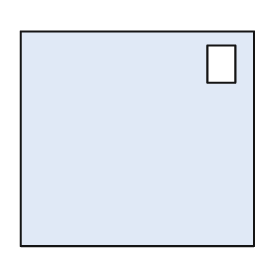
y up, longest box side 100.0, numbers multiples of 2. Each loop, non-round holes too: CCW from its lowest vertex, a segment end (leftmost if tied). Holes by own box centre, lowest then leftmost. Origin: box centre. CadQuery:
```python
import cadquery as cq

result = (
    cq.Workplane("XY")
    .moveTo(-50.0, -46.0)
    .lineTo(50.0, -46.0)
    .lineTo(50.0, 46.0)
    .lineTo(-50.0, 46.0)
    .close()
    .moveTo(30.0, 24.0)
    .lineTo(42.0, 24.0)
    .lineTo(42.0, 40.0)
    .lineTo(30.0, 40.0)
    .close()
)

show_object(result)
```